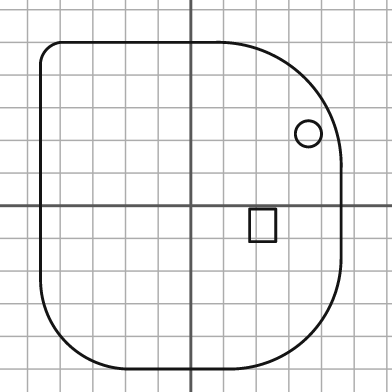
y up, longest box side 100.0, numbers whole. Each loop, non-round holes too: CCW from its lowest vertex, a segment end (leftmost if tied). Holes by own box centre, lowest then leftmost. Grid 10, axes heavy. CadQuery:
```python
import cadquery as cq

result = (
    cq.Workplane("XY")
    .moveTo(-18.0, -50.0)
    .lineTo(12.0, -50.0)
    .threePointArc((36.0, -40.0), (46.0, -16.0))
    .lineTo(46.0, 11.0)
    .threePointArc((35.0, 39.0), (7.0, 50.0))
    .lineTo(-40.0, 50.0)
    .threePointArc((-44.0, 48.0), (-46.0, 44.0))
    .lineTo(-46.0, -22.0)
    .threePointArc((-38.0, -42.0), (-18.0, -50.0))
    .close()
    .moveTo(18.0, -11.0)
    .lineTo(26.0, -11.0)
    .lineTo(26.0, -1.0)
    .lineTo(18.0, -1.0)
    .close()
    .moveTo(36.0, 22.0)
    .circle(4.0)
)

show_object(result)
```